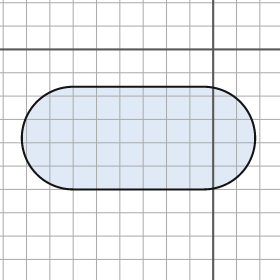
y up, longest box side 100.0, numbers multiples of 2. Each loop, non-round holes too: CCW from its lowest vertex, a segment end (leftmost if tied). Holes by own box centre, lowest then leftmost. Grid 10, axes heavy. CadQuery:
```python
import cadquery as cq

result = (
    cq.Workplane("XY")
    .moveTo(-60.0, -60.0)
    .lineTo(-4.0, -60.0)
    .threePointArc((18.0, -38.0), (-4.0, -16.0))
    .lineTo(-60.0, -16.0)
    .threePointArc((-82.0, -38.0), (-60.0, -60.0))
    .close()
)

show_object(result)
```